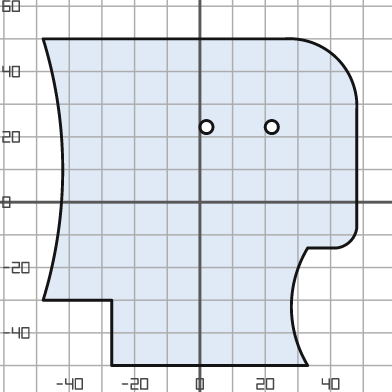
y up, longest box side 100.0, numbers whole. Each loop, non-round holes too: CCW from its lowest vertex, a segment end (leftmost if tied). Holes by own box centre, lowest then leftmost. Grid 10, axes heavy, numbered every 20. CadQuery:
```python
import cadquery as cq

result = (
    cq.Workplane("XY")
    .moveTo(-27.0, -50.0)
    .lineTo(33.0, -50.0)
    .threePointArc((28.0, -32.0), (33.0, -14.0))
    .lineTo(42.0, -14.0)
    .threePointArc((46.0, -12.0), (48.0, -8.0))
    .lineTo(48.0, 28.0)
    .threePointArc((42.0, 44.0), (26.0, 50.0))
    .lineTo(-48.0, 50.0)
    .threePointArc((-42.0, 10.0), (-48.0, -30.0))
    .lineTo(-27.0, -30.0)
    .close()
    .moveTo(2.0, 23.0)
    .circle(2.0)
    .moveTo(22.0, 23.0)
    .circle(2.0)
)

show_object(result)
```